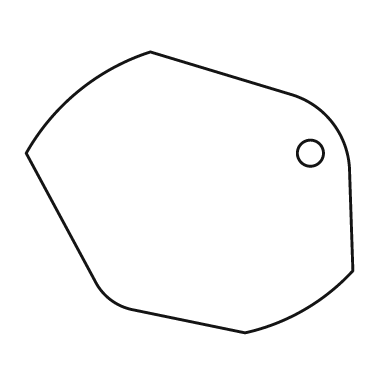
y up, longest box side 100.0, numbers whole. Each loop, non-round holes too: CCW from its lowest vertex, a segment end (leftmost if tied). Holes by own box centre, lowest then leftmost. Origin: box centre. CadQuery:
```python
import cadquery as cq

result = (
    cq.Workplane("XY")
    .moveTo(17.0, -43.0)
    .threePointArc((35.0, -36.0), (50.0, -24.0))
    .lineTo(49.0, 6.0)
    .threePointArc((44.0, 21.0), (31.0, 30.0))
    .lineTo(-12.0, 43.0)
    .threePointArc((-34.0, 31.0), (-50.0, 12.0))
    .lineTo(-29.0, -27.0)
    .threePointArc((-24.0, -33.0), (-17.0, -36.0))
    .close()
    .moveTo(37.0, 12.0)
    .circle(4.0)
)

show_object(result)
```